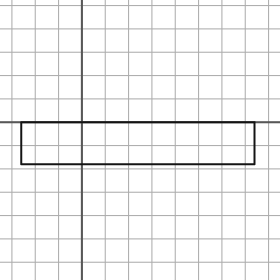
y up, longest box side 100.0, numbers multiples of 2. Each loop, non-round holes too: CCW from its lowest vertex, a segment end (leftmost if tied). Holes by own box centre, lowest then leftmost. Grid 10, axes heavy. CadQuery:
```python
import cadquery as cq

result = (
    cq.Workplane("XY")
    .moveTo(-26.0, -18.0)
    .lineTo(74.0, -18.0)
    .lineTo(74.0, 0.0)
    .lineTo(-26.0, 0.0)
    .close()
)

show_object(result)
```